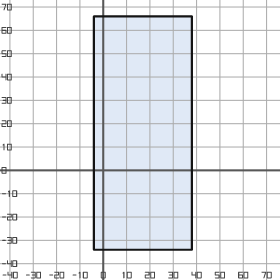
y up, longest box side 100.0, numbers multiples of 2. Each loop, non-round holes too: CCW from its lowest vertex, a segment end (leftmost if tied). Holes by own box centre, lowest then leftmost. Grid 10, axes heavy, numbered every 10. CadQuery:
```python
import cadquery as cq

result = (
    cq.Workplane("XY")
    .moveTo(-4.0, -34.0)
    .lineTo(38.0, -34.0)
    .lineTo(38.0, 66.0)
    .lineTo(-4.0, 66.0)
    .close()
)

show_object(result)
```